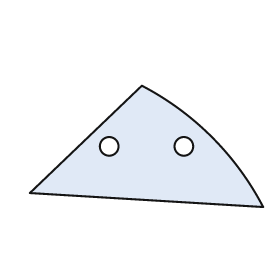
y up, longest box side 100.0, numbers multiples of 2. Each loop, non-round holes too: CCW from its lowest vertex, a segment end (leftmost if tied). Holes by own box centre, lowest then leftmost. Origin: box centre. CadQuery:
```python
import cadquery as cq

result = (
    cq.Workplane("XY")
    .moveTo(50.0, -26.0)
    .threePointArc((28.0, 4.0), (-2.0, 26.0))
    .lineTo(-50.0, -20.0)
    .close()
    .moveTo(-16.0, 0.0)
    .circle(4.0)
    .moveTo(16.0, 0.0)
    .circle(4.0)
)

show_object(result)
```